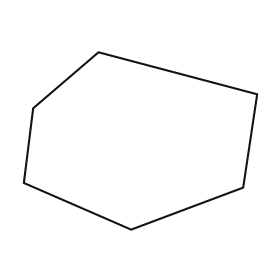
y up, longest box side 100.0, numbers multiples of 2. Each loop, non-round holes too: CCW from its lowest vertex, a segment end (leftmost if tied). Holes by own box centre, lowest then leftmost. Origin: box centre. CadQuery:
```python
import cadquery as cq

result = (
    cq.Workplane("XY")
    .moveTo(-4.0, -38.0)
    .lineTo(44.0, -20.0)
    .lineTo(50.0, 20.0)
    .lineTo(-18.0, 38.0)
    .lineTo(-46.0, 14.0)
    .lineTo(-50.0, -18.0)
    .close()
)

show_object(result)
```